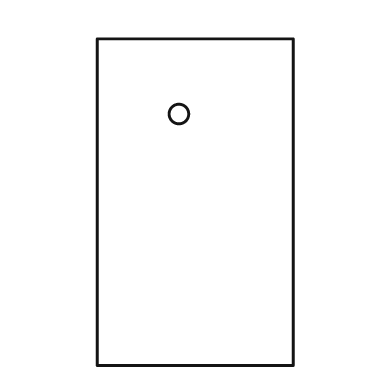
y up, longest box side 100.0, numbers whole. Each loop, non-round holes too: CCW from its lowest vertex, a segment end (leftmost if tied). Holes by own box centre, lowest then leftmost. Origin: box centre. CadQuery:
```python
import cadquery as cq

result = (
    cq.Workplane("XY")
    .moveTo(-30.0, -50.0)
    .lineTo(30.0, -50.0)
    .lineTo(30.0, 50.0)
    .lineTo(-30.0, 50.0)
    .close()
    .moveTo(-5.0, 27.0)
    .circle(3.0)
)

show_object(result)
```